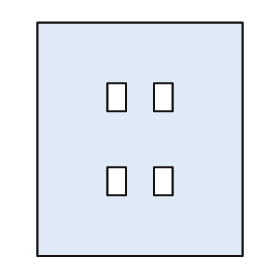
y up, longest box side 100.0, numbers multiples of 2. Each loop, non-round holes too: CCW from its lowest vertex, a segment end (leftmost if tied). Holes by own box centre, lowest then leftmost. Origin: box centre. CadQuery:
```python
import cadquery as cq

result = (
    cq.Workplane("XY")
    .moveTo(-44.0, -50.0)
    .lineTo(44.0, -50.0)
    .lineTo(44.0, 50.0)
    .lineTo(-44.0, 50.0)
    .close()
    .moveTo(-14.0, -24.0)
    .lineTo(-6.0, -24.0)
    .lineTo(-6.0, -12.0)
    .lineTo(-14.0, -12.0)
    .close()
    .moveTo(6.0, -24.0)
    .lineTo(14.0, -24.0)
    .lineTo(14.0, -12.0)
    .lineTo(6.0, -12.0)
    .close()
    .moveTo(-14.0, 12.0)
    .lineTo(-6.0, 12.0)
    .lineTo(-6.0, 24.0)
    .lineTo(-14.0, 24.0)
    .close()
    .moveTo(6.0, 12.0)
    .lineTo(14.0, 12.0)
    .lineTo(14.0, 24.0)
    .lineTo(6.0, 24.0)
    .close()
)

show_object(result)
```